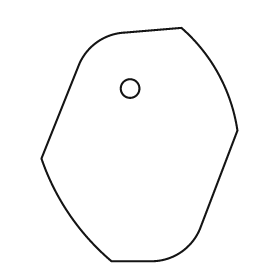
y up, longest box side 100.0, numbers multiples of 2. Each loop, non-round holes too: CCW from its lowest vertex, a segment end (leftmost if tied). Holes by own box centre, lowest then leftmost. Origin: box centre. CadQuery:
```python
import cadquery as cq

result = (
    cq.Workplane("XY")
    .moveTo(-12.0, -50.0)
    .lineTo(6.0, -50.0)
    .threePointArc((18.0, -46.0), (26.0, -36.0))
    .lineTo(42.0, 6.0)
    .threePointArc((34.0, 30.0), (18.0, 50.0))
    .lineTo(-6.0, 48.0)
    .threePointArc((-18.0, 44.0), (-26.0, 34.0))
    .lineTo(-42.0, -6.0)
    .threePointArc((-30.0, -30.0), (-12.0, -50.0))
    .close()
    .moveTo(-4.0, 24.0)
    .circle(4.0)
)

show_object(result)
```